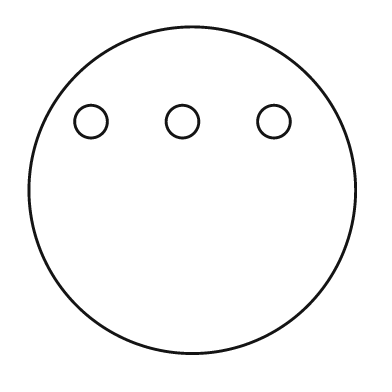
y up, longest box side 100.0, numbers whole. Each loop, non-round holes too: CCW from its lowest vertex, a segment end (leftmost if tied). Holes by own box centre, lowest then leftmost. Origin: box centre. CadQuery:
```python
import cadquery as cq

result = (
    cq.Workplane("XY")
    .moveTo(0.0, 0.0)
    .circle(50.0)
    .moveTo(-31.0, 21.0)
    .circle(5.0)
    .moveTo(-3.0, 21.0)
    .circle(5.0)
    .moveTo(25.0, 21.0)
    .circle(5.0)
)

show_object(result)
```